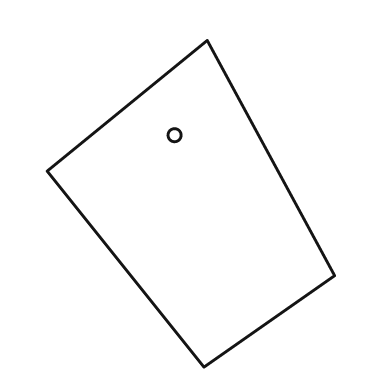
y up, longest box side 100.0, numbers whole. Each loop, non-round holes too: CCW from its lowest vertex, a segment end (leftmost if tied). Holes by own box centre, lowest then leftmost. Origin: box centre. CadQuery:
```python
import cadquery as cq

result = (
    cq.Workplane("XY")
    .moveTo(4.0, -50.0)
    .lineTo(44.0, -22.0)
    .lineTo(5.0, 50.0)
    .lineTo(-44.0, 10.0)
    .close()
    .moveTo(-5.0, 21.0)
    .circle(2.0)
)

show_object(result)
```